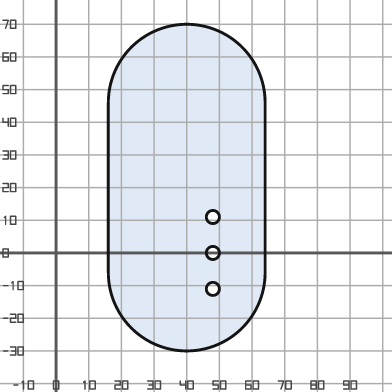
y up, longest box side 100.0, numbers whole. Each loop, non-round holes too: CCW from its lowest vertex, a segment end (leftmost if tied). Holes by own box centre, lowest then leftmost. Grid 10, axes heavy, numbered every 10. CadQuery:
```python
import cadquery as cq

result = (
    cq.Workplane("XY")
    .moveTo(16.0, -6.0)
    .threePointArc((40.0, -30.0), (64.0, -6.0))
    .lineTo(64.0, 46.0)
    .threePointArc((40.0, 70.0), (16.0, 46.0))
    .close()
    .moveTo(48.0, -11.0)
    .circle(2.0)
    .moveTo(48.0, 0.0)
    .circle(2.0)
    .moveTo(48.0, 11.0)
    .circle(2.0)
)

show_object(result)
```